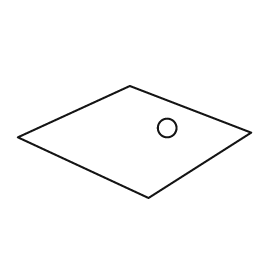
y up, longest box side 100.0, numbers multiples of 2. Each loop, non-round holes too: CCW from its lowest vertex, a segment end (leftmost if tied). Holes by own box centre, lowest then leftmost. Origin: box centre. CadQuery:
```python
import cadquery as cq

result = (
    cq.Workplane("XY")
    .moveTo(6.0, -24.0)
    .lineTo(50.0, 4.0)
    .lineTo(-2.0, 24.0)
    .lineTo(-50.0, 2.0)
    .close()
    .moveTo(14.0, 6.0)
    .circle(4.0)
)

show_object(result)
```